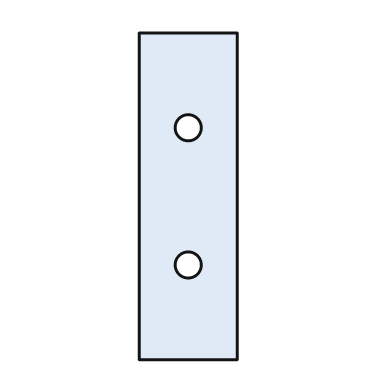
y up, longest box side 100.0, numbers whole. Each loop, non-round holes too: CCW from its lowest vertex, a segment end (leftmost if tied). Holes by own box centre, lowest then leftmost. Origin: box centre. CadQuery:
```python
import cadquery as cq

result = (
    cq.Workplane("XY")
    .moveTo(-15.0, -50.0)
    .lineTo(15.0, -50.0)
    .lineTo(15.0, 50.0)
    .lineTo(-15.0, 50.0)
    .close()
    .moveTo(0.0, -21.0)
    .circle(4.0)
    .moveTo(0.0, 21.0)
    .circle(4.0)
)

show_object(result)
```